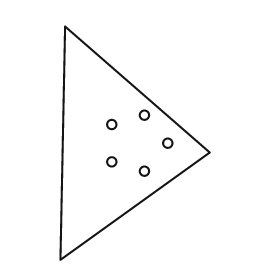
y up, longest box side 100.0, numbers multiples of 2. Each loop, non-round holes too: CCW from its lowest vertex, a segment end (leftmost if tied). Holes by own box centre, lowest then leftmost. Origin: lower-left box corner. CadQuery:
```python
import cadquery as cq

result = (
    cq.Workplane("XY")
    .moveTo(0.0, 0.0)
    .lineTo(64.0, 46.0)
    .lineTo(2.0, 100.0)
    .close()
    .moveTo(36.0, 38.0)
    .circle(2.0)
    .moveTo(22.0, 42.0)
    .circle(2.0)
    .moveTo(46.0, 50.0)
    .circle(2.0)
    .moveTo(22.0, 58.0)
    .circle(2.0)
    .moveTo(36.0, 62.0)
    .circle(2.0)
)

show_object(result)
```